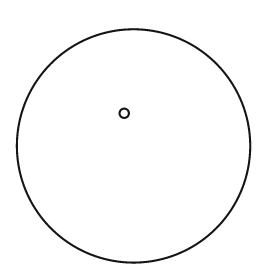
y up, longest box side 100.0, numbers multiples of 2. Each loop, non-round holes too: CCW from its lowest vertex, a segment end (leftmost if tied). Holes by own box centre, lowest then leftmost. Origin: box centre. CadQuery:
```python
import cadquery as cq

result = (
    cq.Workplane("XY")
    .moveTo(0.0, 0.0)
    .circle(50.0)
    .moveTo(-4.0, 14.0)
    .circle(2.0)
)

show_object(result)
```